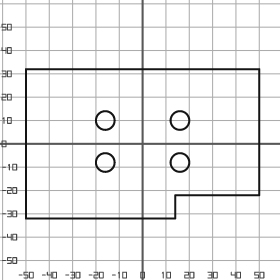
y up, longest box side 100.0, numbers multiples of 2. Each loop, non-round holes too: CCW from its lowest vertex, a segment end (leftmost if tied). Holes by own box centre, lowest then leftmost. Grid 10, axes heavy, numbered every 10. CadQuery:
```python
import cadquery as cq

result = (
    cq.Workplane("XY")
    .moveTo(-50.0, -32.0)
    .lineTo(14.0, -32.0)
    .lineTo(14.0, -22.0)
    .lineTo(50.0, -22.0)
    .lineTo(50.0, 32.0)
    .lineTo(-50.0, 32.0)
    .close()
    .moveTo(-16.0, -8.0)
    .circle(4.0)
    .moveTo(16.0, -8.0)
    .circle(4.0)
    .moveTo(-16.0, 10.0)
    .circle(4.0)
    .moveTo(16.0, 10.0)
    .circle(4.0)
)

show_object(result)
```